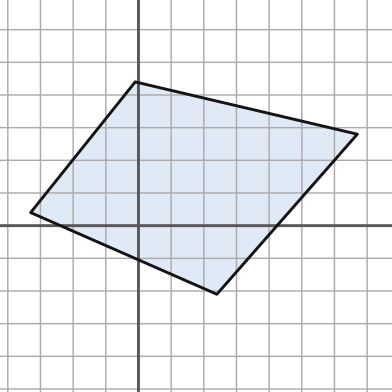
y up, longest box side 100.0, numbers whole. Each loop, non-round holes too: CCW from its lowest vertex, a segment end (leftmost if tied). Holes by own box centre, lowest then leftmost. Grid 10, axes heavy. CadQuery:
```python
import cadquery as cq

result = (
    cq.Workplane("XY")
    .moveTo(24.0, -21.0)
    .lineTo(67.0, 28.0)
    .lineTo(-1.0, 44.0)
    .lineTo(-33.0, 4.0)
    .close()
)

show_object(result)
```